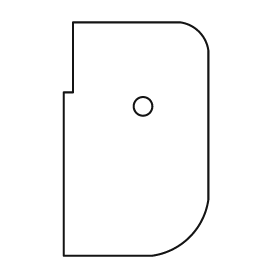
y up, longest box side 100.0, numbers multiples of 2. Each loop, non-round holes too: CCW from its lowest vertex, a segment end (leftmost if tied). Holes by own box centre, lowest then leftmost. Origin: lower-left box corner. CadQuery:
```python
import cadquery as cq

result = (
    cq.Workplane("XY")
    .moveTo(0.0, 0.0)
    .lineTo(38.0, 0.0)
    .threePointArc((54.0, 8.0), (62.0, 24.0))
    .lineTo(62.0, 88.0)
    .threePointArc((58.0, 96.0), (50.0, 100.0))
    .lineTo(4.0, 100.0)
    .lineTo(4.0, 70.0)
    .lineTo(0.0, 70.0)
    .close()
    .moveTo(34.0, 64.0)
    .circle(4.0)
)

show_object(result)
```